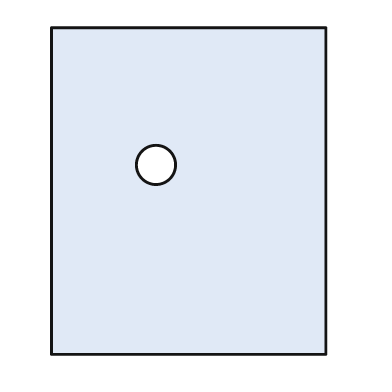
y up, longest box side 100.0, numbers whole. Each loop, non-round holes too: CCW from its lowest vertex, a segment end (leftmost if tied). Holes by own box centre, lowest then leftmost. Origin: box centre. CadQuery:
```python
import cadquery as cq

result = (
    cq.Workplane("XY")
    .moveTo(-42.0, -50.0)
    .lineTo(42.0, -50.0)
    .lineTo(42.0, 50.0)
    .lineTo(-42.0, 50.0)
    .close()
    .moveTo(-10.0, 8.0)
    .circle(6.0)
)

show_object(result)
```